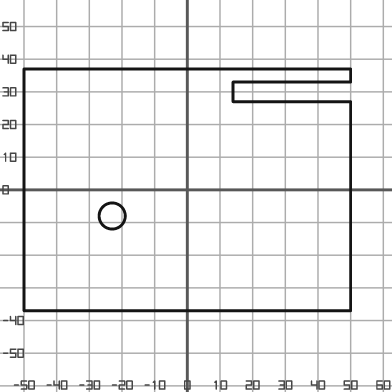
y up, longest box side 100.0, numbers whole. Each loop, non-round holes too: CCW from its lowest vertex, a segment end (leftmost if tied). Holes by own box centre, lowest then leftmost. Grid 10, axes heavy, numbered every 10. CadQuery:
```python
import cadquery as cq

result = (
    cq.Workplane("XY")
    .moveTo(-50.0, -37.0)
    .lineTo(50.0, -37.0)
    .lineTo(50.0, 27.0)
    .lineTo(14.0, 27.0)
    .lineTo(14.0, 33.0)
    .lineTo(50.0, 33.0)
    .lineTo(50.0, 37.0)
    .lineTo(-50.0, 37.0)
    .close()
    .moveTo(-23.0, -8.0)
    .circle(4.0)
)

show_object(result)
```